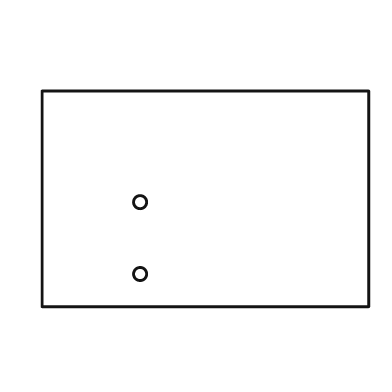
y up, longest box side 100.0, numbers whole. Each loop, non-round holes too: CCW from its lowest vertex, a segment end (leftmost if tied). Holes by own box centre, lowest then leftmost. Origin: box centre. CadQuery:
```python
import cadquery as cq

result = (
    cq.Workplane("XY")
    .moveTo(-50.0, -33.0)
    .lineTo(50.0, -33.0)
    .lineTo(50.0, 33.0)
    .lineTo(-50.0, 33.0)
    .close()
    .moveTo(-20.0, -23.0)
    .circle(2.0)
    .moveTo(-20.0, -1.0)
    .circle(2.0)
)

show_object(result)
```